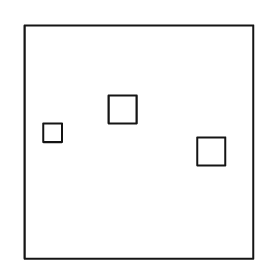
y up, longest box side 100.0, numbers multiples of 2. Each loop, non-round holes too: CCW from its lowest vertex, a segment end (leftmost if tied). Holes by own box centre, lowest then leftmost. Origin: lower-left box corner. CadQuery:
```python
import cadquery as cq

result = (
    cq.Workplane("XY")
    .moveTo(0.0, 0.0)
    .lineTo(98.0, 0.0)
    .lineTo(98.0, 100.0)
    .lineTo(0.0, 100.0)
    .close()
    .moveTo(74.0, 40.0)
    .lineTo(86.0, 40.0)
    .lineTo(86.0, 52.0)
    .lineTo(74.0, 52.0)
    .close()
    .moveTo(8.0, 50.0)
    .lineTo(16.0, 50.0)
    .lineTo(16.0, 58.0)
    .lineTo(8.0, 58.0)
    .close()
    .moveTo(36.0, 58.0)
    .lineTo(48.0, 58.0)
    .lineTo(48.0, 70.0)
    .lineTo(36.0, 70.0)
    .close()
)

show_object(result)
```